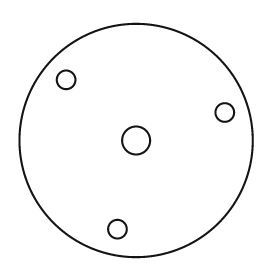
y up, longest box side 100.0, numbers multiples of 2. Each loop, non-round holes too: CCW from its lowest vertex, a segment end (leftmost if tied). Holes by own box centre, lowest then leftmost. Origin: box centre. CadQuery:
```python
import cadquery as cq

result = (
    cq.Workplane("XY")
    .moveTo(0.0, 0.0)
    .circle(50.0)
    .moveTo(-8.0, -38.0)
    .circle(4.0)
    .moveTo(0.0, 0.0)
    .circle(6.0)
    .moveTo(38.0, 12.0)
    .circle(4.0)
    .moveTo(-30.0, 26.0)
    .circle(4.0)
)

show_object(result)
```